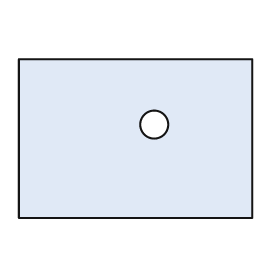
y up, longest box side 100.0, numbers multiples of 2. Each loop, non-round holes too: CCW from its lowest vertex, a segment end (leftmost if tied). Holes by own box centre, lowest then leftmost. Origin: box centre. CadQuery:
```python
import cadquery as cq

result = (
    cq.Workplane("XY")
    .moveTo(-50.0, -34.0)
    .lineTo(50.0, -34.0)
    .lineTo(50.0, 34.0)
    .lineTo(-50.0, 34.0)
    .close()
    .moveTo(8.0, 6.0)
    .circle(6.0)
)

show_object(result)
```